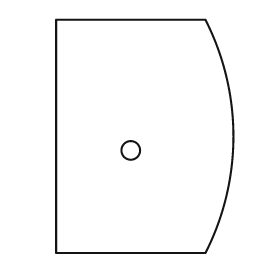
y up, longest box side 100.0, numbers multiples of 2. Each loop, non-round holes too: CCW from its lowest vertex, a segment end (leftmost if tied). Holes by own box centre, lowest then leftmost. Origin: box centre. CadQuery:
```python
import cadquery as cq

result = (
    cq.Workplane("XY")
    .moveTo(-38.0, -50.0)
    .lineTo(26.0, -50.0)
    .threePointArc((38.0, 0.0), (26.0, 50.0))
    .lineTo(-38.0, 50.0)
    .close()
    .moveTo(-6.0, -6.0)
    .circle(4.0)
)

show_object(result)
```